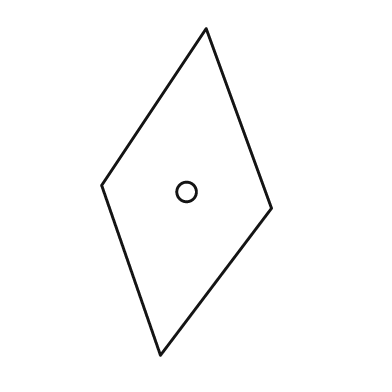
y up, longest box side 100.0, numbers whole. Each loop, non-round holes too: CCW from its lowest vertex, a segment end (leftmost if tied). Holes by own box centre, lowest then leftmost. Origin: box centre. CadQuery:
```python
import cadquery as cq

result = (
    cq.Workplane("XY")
    .moveTo(-8.0, -50.0)
    .lineTo(26.0, -5.0)
    .lineTo(6.0, 50.0)
    .lineTo(-26.0, 2.0)
    .close()
    .moveTo(0.0, 0.0)
    .circle(3.0)
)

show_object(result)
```